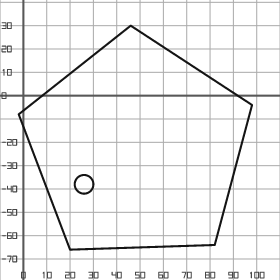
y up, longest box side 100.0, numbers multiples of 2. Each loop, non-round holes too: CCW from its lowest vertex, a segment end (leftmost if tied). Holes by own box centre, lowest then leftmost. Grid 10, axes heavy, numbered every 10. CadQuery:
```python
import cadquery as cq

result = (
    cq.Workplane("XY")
    .moveTo(20.0, -66.0)
    .lineTo(82.0, -64.0)
    .lineTo(98.0, -4.0)
    .lineTo(46.0, 30.0)
    .lineTo(-2.0, -8.0)
    .close()
    .moveTo(26.0, -38.0)
    .circle(4.0)
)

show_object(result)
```